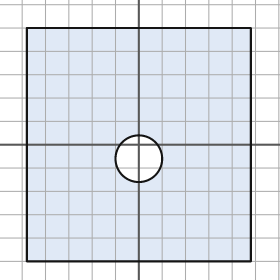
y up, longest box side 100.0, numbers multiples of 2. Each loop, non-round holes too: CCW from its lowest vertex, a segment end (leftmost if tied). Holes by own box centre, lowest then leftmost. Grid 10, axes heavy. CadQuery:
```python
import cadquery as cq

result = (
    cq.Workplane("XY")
    .moveTo(-48.0, -50.0)
    .lineTo(48.0, -50.0)
    .lineTo(48.0, 50.0)
    .lineTo(-48.0, 50.0)
    .close()
    .moveTo(0.0, -6.0)
    .circle(10.0)
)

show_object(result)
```